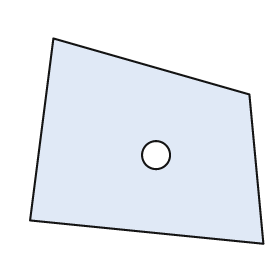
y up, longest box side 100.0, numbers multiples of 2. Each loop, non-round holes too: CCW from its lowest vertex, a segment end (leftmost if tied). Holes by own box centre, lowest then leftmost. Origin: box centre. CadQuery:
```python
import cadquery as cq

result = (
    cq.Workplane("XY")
    .moveTo(50.0, -44.0)
    .lineTo(44.0, 20.0)
    .lineTo(-40.0, 44.0)
    .lineTo(-50.0, -34.0)
    .close()
    .moveTo(4.0, -6.0)
    .circle(6.0)
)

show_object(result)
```